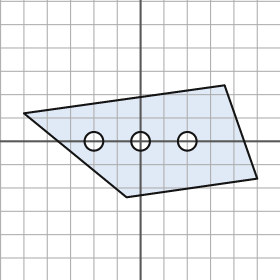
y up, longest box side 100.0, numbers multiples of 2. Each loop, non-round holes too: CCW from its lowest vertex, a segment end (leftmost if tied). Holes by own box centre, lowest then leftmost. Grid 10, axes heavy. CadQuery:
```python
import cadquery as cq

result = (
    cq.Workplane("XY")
    .moveTo(-6.0, -24.0)
    .lineTo(50.0, -16.0)
    .lineTo(36.0, 24.0)
    .lineTo(-50.0, 12.0)
    .close()
    .moveTo(-20.0, 0.0)
    .circle(4.0)
    .moveTo(0.0, 0.0)
    .circle(4.0)
    .moveTo(20.0, 0.0)
    .circle(4.0)
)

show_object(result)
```